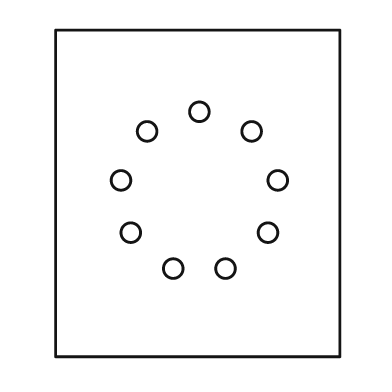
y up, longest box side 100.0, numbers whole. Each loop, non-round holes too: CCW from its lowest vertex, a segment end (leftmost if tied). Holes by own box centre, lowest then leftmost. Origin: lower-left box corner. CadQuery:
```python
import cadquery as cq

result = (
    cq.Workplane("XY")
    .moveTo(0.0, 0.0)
    .lineTo(87.0, 0.0)
    .lineTo(87.0, 100.0)
    .lineTo(0.0, 100.0)
    .close()
    .moveTo(36.0, 27.0)
    .circle(3.0)
    .moveTo(52.0, 27.0)
    .circle(3.0)
    .moveTo(23.0, 38.0)
    .circle(3.0)
    .moveTo(65.0, 38.0)
    .circle(3.0)
    .moveTo(20.0, 54.0)
    .circle(3.0)
    .moveTo(68.0, 54.0)
    .circle(3.0)
    .moveTo(28.0, 69.0)
    .circle(3.0)
    .moveTo(60.0, 69.0)
    .circle(3.0)
    .moveTo(44.0, 75.0)
    .circle(3.0)
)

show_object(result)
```